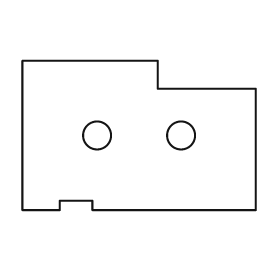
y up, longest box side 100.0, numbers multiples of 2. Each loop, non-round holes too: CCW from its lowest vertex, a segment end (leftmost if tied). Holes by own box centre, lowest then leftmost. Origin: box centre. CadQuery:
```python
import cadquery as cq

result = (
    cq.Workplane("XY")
    .moveTo(-50.0, -32.0)
    .lineTo(-34.0, -32.0)
    .lineTo(-34.0, -28.0)
    .lineTo(-20.0, -28.0)
    .lineTo(-20.0, -32.0)
    .lineTo(50.0, -32.0)
    .lineTo(50.0, 20.0)
    .lineTo(8.0, 20.0)
    .lineTo(8.0, 32.0)
    .lineTo(-50.0, 32.0)
    .close()
    .moveTo(-18.0, 0.0)
    .circle(6.0)
    .moveTo(18.0, 0.0)
    .circle(6.0)
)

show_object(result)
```